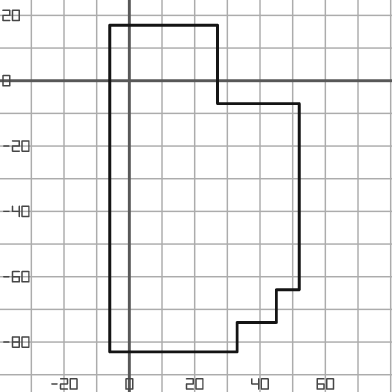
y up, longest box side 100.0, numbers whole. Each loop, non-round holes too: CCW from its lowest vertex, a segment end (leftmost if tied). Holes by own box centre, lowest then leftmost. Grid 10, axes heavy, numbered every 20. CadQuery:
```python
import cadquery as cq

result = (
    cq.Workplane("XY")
    .moveTo(-6.0, -83.0)
    .lineTo(33.0, -83.0)
    .lineTo(33.0, -74.0)
    .lineTo(45.0, -74.0)
    .lineTo(45.0, -64.0)
    .lineTo(52.0, -64.0)
    .lineTo(52.0, -7.0)
    .lineTo(27.0, -7.0)
    .lineTo(27.0, 17.0)
    .lineTo(-6.0, 17.0)
    .close()
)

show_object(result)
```